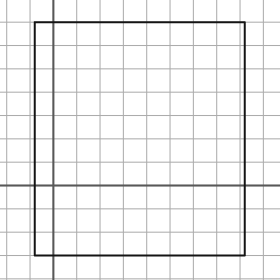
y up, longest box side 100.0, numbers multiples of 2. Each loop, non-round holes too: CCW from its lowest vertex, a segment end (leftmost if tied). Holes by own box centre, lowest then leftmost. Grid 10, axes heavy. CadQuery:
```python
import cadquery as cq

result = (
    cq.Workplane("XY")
    .moveTo(-8.0, -30.0)
    .lineTo(82.0, -30.0)
    .lineTo(82.0, 70.0)
    .lineTo(-8.0, 70.0)
    .close()
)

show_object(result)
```